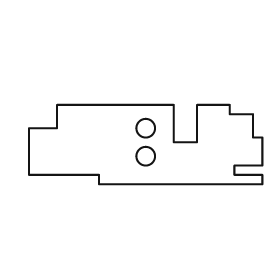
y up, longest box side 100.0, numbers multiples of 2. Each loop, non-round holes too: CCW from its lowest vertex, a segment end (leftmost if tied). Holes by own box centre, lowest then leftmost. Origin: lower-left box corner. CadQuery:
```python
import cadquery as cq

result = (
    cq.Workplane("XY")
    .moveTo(30.0, 0.0)
    .lineTo(100.0, 0.0)
    .lineTo(100.0, 4.0)
    .lineTo(88.0, 4.0)
    .lineTo(88.0, 8.0)
    .lineTo(100.0, 8.0)
    .lineTo(100.0, 20.0)
    .lineTo(96.0, 20.0)
    .lineTo(96.0, 30.0)
    .lineTo(86.0, 30.0)
    .lineTo(86.0, 34.0)
    .lineTo(72.0, 34.0)
    .lineTo(72.0, 18.0)
    .lineTo(62.0, 18.0)
    .lineTo(62.0, 34.0)
    .lineTo(12.0, 34.0)
    .lineTo(12.0, 24.0)
    .lineTo(0.0, 24.0)
    .lineTo(0.0, 4.0)
    .lineTo(30.0, 4.0)
    .close()
    .moveTo(50.0, 12.0)
    .circle(4.0)
    .moveTo(50.0, 24.0)
    .circle(4.0)
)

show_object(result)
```